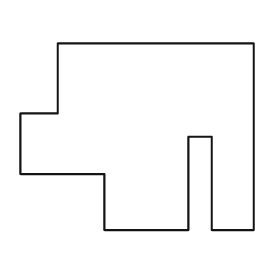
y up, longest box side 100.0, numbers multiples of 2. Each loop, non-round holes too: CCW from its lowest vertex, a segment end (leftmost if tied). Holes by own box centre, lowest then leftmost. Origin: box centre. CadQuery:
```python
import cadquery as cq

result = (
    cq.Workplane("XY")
    .moveTo(-14.0, -40.0)
    .lineTo(22.0, -40.0)
    .lineTo(22.0, 0.0)
    .lineTo(32.0, 0.0)
    .lineTo(32.0, -40.0)
    .lineTo(50.0, -40.0)
    .lineTo(50.0, 40.0)
    .lineTo(-34.0, 40.0)
    .lineTo(-34.0, 10.0)
    .lineTo(-50.0, 10.0)
    .lineTo(-50.0, -16.0)
    .lineTo(-14.0, -16.0)
    .close()
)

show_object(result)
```